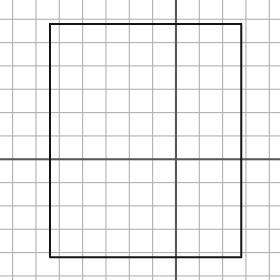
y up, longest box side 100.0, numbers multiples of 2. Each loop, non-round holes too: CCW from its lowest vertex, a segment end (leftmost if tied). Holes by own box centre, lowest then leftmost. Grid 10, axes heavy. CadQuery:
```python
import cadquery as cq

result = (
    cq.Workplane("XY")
    .moveTo(-54.0, -42.0)
    .lineTo(28.0, -42.0)
    .lineTo(28.0, 58.0)
    .lineTo(-54.0, 58.0)
    .close()
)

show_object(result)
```